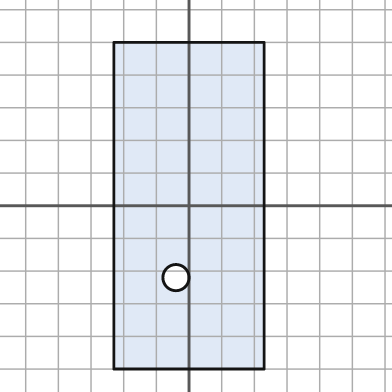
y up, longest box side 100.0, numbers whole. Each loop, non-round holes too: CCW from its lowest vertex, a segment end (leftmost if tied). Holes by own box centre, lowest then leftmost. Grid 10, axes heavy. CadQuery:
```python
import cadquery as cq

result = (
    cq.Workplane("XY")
    .moveTo(-23.0, -50.0)
    .lineTo(23.0, -50.0)
    .lineTo(23.0, 50.0)
    .lineTo(-23.0, 50.0)
    .close()
    .moveTo(-4.0, -22.0)
    .circle(4.0)
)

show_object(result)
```